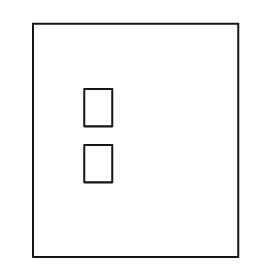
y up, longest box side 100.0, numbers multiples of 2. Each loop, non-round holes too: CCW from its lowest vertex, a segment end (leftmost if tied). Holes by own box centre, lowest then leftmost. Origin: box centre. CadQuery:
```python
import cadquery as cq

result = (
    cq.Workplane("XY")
    .moveTo(-44.0, -50.0)
    .lineTo(44.0, -50.0)
    .lineTo(44.0, 50.0)
    .lineTo(-44.0, 50.0)
    .close()
    .moveTo(-22.0, -18.0)
    .lineTo(-10.0, -18.0)
    .lineTo(-10.0, -2.0)
    .lineTo(-22.0, -2.0)
    .close()
    .moveTo(-22.0, 6.0)
    .lineTo(-10.0, 6.0)
    .lineTo(-10.0, 22.0)
    .lineTo(-22.0, 22.0)
    .close()
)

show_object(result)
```